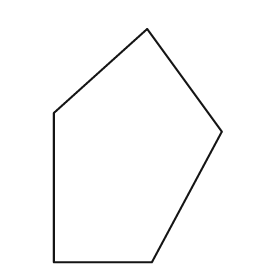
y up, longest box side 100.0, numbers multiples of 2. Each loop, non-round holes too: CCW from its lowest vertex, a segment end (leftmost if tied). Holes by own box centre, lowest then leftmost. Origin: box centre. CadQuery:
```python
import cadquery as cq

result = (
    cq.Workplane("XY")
    .moveTo(-36.0, -50.0)
    .lineTo(6.0, -50.0)
    .lineTo(36.0, 6.0)
    .lineTo(4.0, 50.0)
    .lineTo(-36.0, 14.0)
    .close()
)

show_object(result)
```